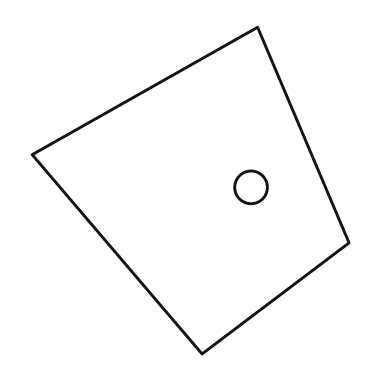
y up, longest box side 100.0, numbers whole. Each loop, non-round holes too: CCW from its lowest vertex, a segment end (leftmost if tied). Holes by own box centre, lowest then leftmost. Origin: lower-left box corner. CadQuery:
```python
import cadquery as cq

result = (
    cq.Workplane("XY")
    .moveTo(52.0, 0.0)
    .lineTo(97.0, 34.0)
    .lineTo(69.0, 100.0)
    .lineTo(0.0, 61.0)
    .close()
    .moveTo(67.0, 51.0)
    .circle(5.0)
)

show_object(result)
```